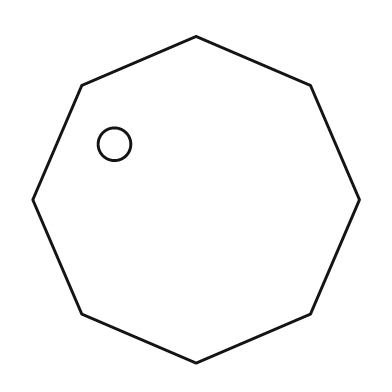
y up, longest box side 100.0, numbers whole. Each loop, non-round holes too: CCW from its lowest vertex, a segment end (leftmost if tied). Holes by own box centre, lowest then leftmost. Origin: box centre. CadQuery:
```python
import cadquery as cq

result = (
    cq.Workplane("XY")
    .moveTo(0.0, -50.0)
    .lineTo(35.0, -35.0)
    .lineTo(50.0, 0.0)
    .lineTo(35.0, 35.0)
    .lineTo(0.0, 50.0)
    .lineTo(-35.0, 35.0)
    .lineTo(-50.0, 0.0)
    .lineTo(-35.0, -35.0)
    .close()
    .moveTo(-25.0, 17.0)
    .circle(5.0)
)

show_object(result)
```